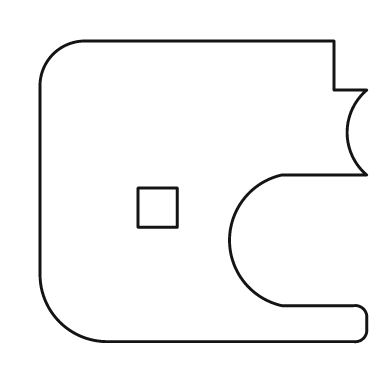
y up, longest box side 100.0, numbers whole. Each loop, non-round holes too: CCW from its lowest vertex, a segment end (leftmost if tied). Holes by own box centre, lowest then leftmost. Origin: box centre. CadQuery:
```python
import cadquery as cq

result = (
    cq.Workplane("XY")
    .moveTo(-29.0, -46.0)
    .lineTo(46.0, -46.0)
    .threePointArc((49.0, -45.0), (50.0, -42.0))
    .lineTo(50.0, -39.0)
    .threePointArc((49.0, -36.0), (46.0, -35.0))
    .lineTo(24.0, -35.0)
    .threePointArc((8.0, -15.0), (24.0, 5.0))
    .lineTo(50.0, 5.0)
    .threePointArc((44.0, 18.0), (50.0, 31.0))
    .lineTo(40.0, 31.0)
    .lineTo(40.0, 46.0)
    .lineTo(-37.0, 46.0)
    .threePointArc((-46.0, 42.0), (-50.0, 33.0))
    .lineTo(-50.0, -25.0)
    .threePointArc((-44.0, -40.0), (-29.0, -46.0))
    .close()
    .moveTo(-20.0, -11.0)
    .lineTo(-8.0, -11.0)
    .lineTo(-8.0, 1.0)
    .lineTo(-20.0, 1.0)
    .close()
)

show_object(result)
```